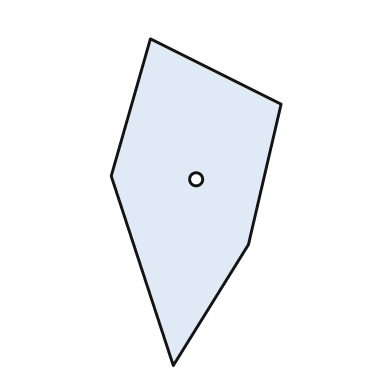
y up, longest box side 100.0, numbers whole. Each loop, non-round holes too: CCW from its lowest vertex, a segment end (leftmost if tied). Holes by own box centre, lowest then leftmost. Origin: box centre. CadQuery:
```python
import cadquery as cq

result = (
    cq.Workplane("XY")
    .moveTo(-7.0, -50.0)
    .lineTo(16.0, -13.0)
    .lineTo(26.0, 30.0)
    .lineTo(-14.0, 50.0)
    .lineTo(-26.0, 8.0)
    .close()
    .moveTo(0.0, 7.0)
    .circle(2.0)
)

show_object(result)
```